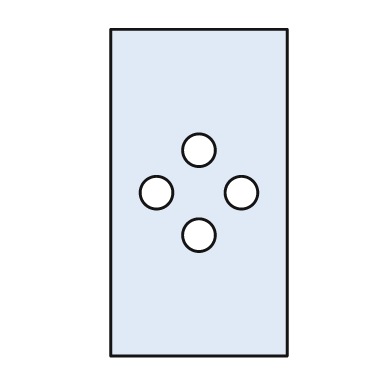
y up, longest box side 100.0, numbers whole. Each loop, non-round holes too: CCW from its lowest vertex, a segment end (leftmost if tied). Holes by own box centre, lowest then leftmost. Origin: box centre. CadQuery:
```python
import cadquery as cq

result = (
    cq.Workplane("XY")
    .moveTo(-27.0, -50.0)
    .lineTo(27.0, -50.0)
    .lineTo(27.0, 50.0)
    .lineTo(-27.0, 50.0)
    .close()
    .moveTo(0.0, -13.0)
    .circle(5.0)
    .moveTo(-13.0, 0.0)
    .circle(5.0)
    .moveTo(13.0, 0.0)
    .circle(5.0)
    .moveTo(0.0, 13.0)
    .circle(5.0)
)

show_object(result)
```